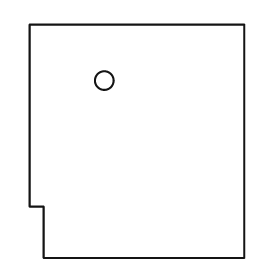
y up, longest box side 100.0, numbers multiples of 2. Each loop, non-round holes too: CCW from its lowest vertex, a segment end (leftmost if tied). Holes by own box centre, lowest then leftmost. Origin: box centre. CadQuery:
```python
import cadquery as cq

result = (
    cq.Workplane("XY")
    .moveTo(-40.0, -50.0)
    .lineTo(46.0, -50.0)
    .lineTo(46.0, 50.0)
    .lineTo(-46.0, 50.0)
    .lineTo(-46.0, -28.0)
    .lineTo(-40.0, -28.0)
    .close()
    .moveTo(-14.0, 26.0)
    .circle(4.0)
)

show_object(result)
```